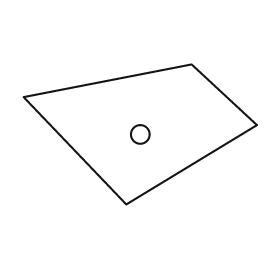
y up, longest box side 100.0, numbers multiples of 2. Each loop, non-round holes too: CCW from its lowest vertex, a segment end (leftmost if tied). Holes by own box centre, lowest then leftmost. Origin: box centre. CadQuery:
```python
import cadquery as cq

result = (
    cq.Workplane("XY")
    .moveTo(-6.0, -30.0)
    .lineTo(50.0, 4.0)
    .lineTo(22.0, 30.0)
    .lineTo(-50.0, 16.0)
    .close()
    .moveTo(0.0, 0.0)
    .circle(4.0)
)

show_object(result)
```